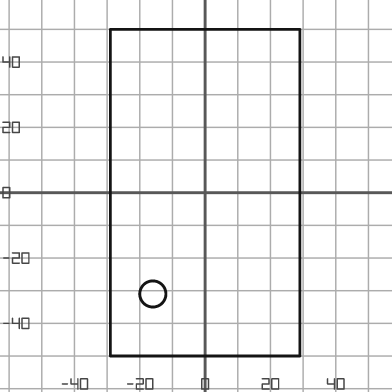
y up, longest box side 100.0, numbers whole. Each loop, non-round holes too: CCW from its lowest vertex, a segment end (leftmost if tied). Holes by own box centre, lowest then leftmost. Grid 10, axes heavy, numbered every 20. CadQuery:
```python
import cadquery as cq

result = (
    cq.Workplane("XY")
    .moveTo(-29.0, -50.0)
    .lineTo(29.0, -50.0)
    .lineTo(29.0, 50.0)
    .lineTo(-29.0, 50.0)
    .close()
    .moveTo(-16.0, -31.0)
    .circle(4.0)
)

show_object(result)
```